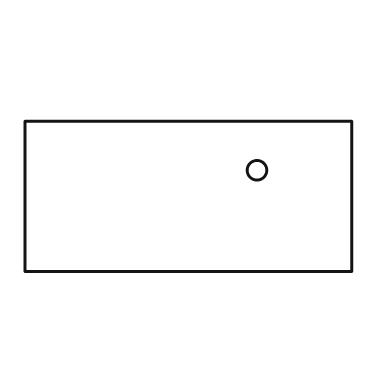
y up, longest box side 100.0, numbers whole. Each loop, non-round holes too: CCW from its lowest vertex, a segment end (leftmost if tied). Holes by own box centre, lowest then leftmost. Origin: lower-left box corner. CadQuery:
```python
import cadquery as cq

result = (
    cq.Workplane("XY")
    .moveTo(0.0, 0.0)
    .lineTo(100.0, 0.0)
    .lineTo(100.0, 46.0)
    .lineTo(0.0, 46.0)
    .close()
    .moveTo(71.0, 31.0)
    .circle(3.0)
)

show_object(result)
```